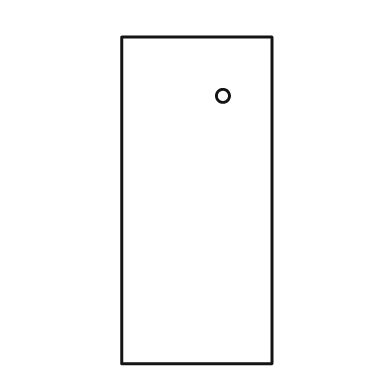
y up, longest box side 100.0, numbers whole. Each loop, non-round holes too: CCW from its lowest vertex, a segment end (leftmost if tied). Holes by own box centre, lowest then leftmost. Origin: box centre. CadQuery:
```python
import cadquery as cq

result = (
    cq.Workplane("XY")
    .moveTo(-23.0, -50.0)
    .lineTo(23.0, -50.0)
    .lineTo(23.0, 50.0)
    .lineTo(-23.0, 50.0)
    .close()
    .moveTo(8.0, 32.0)
    .circle(2.0)
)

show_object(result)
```